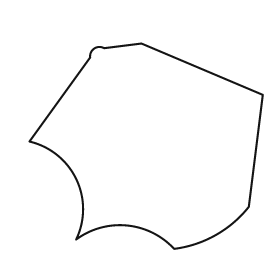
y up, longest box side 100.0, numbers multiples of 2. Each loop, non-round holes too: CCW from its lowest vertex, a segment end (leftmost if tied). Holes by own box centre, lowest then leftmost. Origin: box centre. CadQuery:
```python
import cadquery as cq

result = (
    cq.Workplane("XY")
    .moveTo(12.0, -44.0)
    .threePointArc((30.0, -38.0), (44.0, -26.0))
    .lineTo(50.0, 22.0)
    .lineTo(-2.0, 44.0)
    .lineTo(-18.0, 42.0)
    .threePointArc((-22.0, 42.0), (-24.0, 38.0))
    .lineTo(-50.0, 2.0)
    .threePointArc((-30.0, -14.0), (-30.0, -40.0))
    .threePointArc((-8.0, -34.0), (12.0, -44.0))
    .close()
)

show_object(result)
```